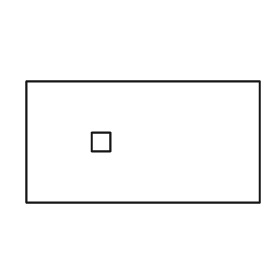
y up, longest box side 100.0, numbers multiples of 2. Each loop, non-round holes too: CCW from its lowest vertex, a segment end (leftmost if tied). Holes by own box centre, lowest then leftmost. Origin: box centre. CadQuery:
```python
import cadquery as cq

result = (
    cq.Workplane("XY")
    .moveTo(-50.0, -26.0)
    .lineTo(50.0, -26.0)
    .lineTo(50.0, 26.0)
    .lineTo(-50.0, 26.0)
    .close()
    .moveTo(-22.0, -4.0)
    .lineTo(-14.0, -4.0)
    .lineTo(-14.0, 4.0)
    .lineTo(-22.0, 4.0)
    .close()
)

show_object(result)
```